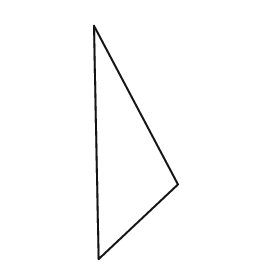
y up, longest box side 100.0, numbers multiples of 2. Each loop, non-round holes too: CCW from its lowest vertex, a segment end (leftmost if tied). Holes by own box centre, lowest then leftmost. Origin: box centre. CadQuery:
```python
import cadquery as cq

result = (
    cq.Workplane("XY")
    .moveTo(-16.0, -50.0)
    .lineTo(18.0, -18.0)
    .lineTo(-18.0, 50.0)
    .close()
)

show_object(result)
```